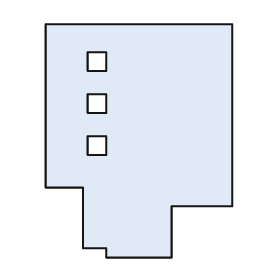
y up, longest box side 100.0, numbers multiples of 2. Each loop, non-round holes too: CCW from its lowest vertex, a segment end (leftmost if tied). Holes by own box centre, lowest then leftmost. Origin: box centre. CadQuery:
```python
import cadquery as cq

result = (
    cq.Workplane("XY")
    .moveTo(-14.0, -50.0)
    .lineTo(14.0, -50.0)
    .lineTo(14.0, -28.0)
    .lineTo(40.0, -28.0)
    .lineTo(40.0, 50.0)
    .lineTo(-40.0, 50.0)
    .lineTo(-40.0, -20.0)
    .lineTo(-24.0, -20.0)
    .lineTo(-24.0, -46.0)
    .lineTo(-14.0, -46.0)
    .close()
    .moveTo(-22.0, -6.0)
    .lineTo(-14.0, -6.0)
    .lineTo(-14.0, 2.0)
    .lineTo(-22.0, 2.0)
    .close()
    .moveTo(-22.0, 12.0)
    .lineTo(-14.0, 12.0)
    .lineTo(-14.0, 20.0)
    .lineTo(-22.0, 20.0)
    .close()
    .moveTo(-22.0, 30.0)
    .lineTo(-14.0, 30.0)
    .lineTo(-14.0, 38.0)
    .lineTo(-22.0, 38.0)
    .close()
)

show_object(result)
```